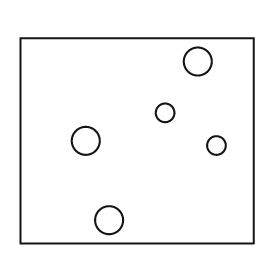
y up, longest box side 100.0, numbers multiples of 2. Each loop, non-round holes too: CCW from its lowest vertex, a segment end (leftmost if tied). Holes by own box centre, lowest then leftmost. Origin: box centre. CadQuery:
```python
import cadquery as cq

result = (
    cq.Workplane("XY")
    .moveTo(-50.0, -44.0)
    .lineTo(50.0, -44.0)
    .lineTo(50.0, 44.0)
    .lineTo(-50.0, 44.0)
    .close()
    .moveTo(-12.0, -34.0)
    .circle(6.0)
    .moveTo(34.0, -2.0)
    .circle(4.0)
    .moveTo(-22.0, 0.0)
    .circle(6.0)
    .moveTo(12.0, 12.0)
    .circle(4.0)
    .moveTo(26.0, 34.0)
    .circle(6.0)
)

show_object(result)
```